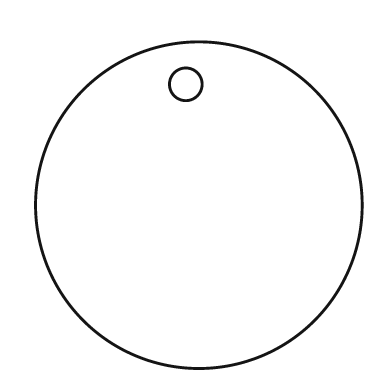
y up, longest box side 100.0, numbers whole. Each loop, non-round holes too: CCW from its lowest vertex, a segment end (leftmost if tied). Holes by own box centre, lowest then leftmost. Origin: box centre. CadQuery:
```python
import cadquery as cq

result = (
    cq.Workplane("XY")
    .moveTo(0.0, 0.0)
    .circle(50.0)
    .moveTo(-4.0, 37.0)
    .circle(5.0)
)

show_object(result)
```